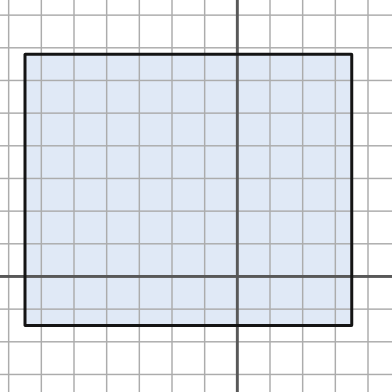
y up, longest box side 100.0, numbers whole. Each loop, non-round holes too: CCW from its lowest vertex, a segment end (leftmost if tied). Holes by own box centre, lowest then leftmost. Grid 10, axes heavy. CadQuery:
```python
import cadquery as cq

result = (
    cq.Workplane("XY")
    .moveTo(-65.0, -15.0)
    .lineTo(35.0, -15.0)
    .lineTo(35.0, 68.0)
    .lineTo(-65.0, 68.0)
    .close()
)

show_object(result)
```